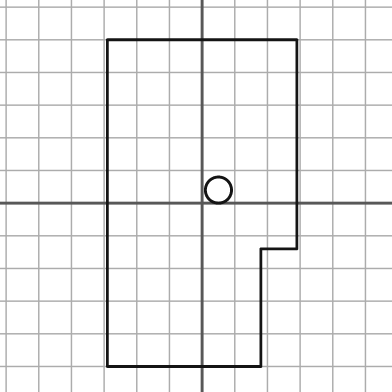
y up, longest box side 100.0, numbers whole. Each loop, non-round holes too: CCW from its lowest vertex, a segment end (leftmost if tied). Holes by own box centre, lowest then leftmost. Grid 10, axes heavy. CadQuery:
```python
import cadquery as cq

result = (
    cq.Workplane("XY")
    .moveTo(-29.0, -50.0)
    .lineTo(18.0, -50.0)
    .lineTo(18.0, -14.0)
    .lineTo(29.0, -14.0)
    .lineTo(29.0, 50.0)
    .lineTo(-29.0, 50.0)
    .close()
    .moveTo(5.0, 4.0)
    .circle(4.0)
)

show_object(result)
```